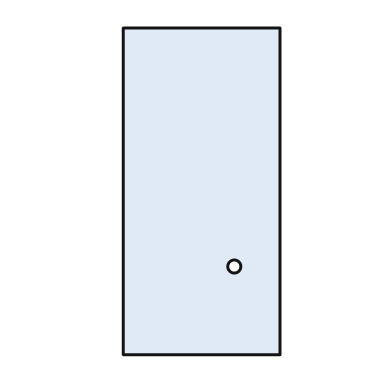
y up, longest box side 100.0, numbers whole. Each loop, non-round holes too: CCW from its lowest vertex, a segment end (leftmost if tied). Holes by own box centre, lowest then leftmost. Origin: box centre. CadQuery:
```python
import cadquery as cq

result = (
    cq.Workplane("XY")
    .moveTo(-24.0, -50.0)
    .lineTo(24.0, -50.0)
    .lineTo(24.0, 50.0)
    .lineTo(-24.0, 50.0)
    .close()
    .moveTo(10.0, -23.0)
    .circle(2.0)
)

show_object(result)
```